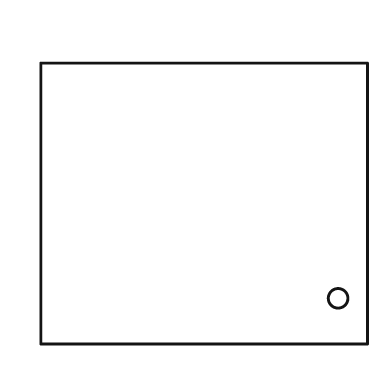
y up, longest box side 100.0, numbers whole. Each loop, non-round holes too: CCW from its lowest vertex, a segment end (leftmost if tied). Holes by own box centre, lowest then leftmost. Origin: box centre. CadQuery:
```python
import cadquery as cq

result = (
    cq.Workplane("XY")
    .moveTo(-50.0, -43.0)
    .lineTo(50.0, -43.0)
    .lineTo(50.0, 43.0)
    .lineTo(-50.0, 43.0)
    .close()
    .moveTo(41.0, -29.0)
    .circle(3.0)
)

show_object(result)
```